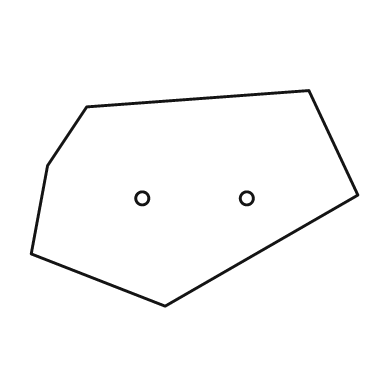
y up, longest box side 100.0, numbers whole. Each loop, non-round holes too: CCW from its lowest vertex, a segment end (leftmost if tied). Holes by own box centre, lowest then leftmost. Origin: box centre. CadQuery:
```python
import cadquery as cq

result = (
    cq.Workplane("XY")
    .moveTo(-9.0, -33.0)
    .lineTo(50.0, 1.0)
    .lineTo(35.0, 33.0)
    .lineTo(-33.0, 28.0)
    .lineTo(-45.0, 10.0)
    .lineTo(-50.0, -17.0)
    .close()
    .moveTo(-16.0, 0.0)
    .circle(2.0)
    .moveTo(16.0, 0.0)
    .circle(2.0)
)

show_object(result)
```